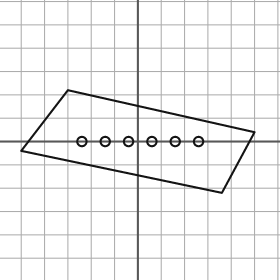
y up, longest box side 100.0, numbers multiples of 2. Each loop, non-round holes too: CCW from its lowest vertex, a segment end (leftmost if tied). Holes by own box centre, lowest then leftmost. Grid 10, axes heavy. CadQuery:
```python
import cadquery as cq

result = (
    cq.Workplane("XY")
    .moveTo(36.0, -22.0)
    .lineTo(50.0, 4.0)
    .lineTo(-30.0, 22.0)
    .lineTo(-50.0, -4.0)
    .close()
    .moveTo(-24.0, 0.0)
    .circle(2.0)
    .moveTo(-14.0, 0.0)
    .circle(2.0)
    .moveTo(-4.0, 0.0)
    .circle(2.0)
    .moveTo(6.0, 0.0)
    .circle(2.0)
    .moveTo(16.0, 0.0)
    .circle(2.0)
    .moveTo(26.0, 0.0)
    .circle(2.0)
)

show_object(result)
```